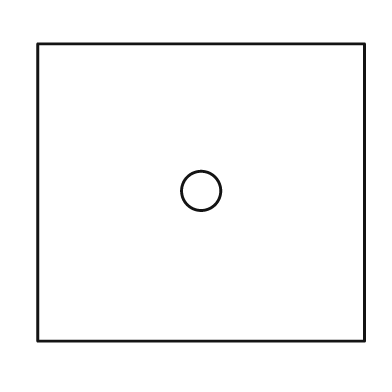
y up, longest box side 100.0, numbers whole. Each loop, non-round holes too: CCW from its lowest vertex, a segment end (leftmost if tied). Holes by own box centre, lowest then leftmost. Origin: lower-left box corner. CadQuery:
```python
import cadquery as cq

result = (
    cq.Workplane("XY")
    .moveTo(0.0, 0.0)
    .lineTo(100.0, 0.0)
    .lineTo(100.0, 91.0)
    .lineTo(0.0, 91.0)
    .close()
    .moveTo(50.0, 46.0)
    .circle(6.0)
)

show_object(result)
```